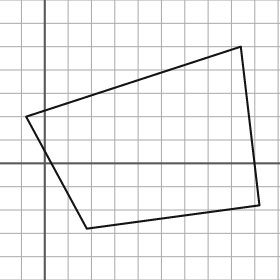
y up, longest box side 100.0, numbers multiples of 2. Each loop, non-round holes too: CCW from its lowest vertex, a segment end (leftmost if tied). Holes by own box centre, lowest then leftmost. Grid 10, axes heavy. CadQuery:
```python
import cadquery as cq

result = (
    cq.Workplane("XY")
    .moveTo(18.0, -28.0)
    .lineTo(92.0, -18.0)
    .lineTo(84.0, 50.0)
    .lineTo(-8.0, 20.0)
    .close()
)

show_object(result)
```